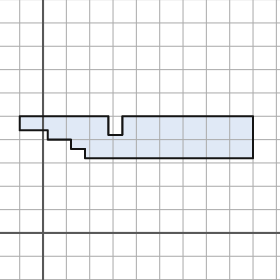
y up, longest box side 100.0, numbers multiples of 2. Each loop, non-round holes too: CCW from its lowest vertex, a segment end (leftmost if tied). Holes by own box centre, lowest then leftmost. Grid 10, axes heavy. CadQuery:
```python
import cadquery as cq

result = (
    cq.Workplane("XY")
    .moveTo(18.0, 32.0)
    .lineTo(90.0, 32.0)
    .lineTo(90.0, 50.0)
    .lineTo(34.0, 50.0)
    .lineTo(34.0, 42.0)
    .lineTo(28.0, 42.0)
    .lineTo(28.0, 50.0)
    .lineTo(-10.0, 50.0)
    .lineTo(-10.0, 44.0)
    .lineTo(2.0, 44.0)
    .lineTo(2.0, 40.0)
    .lineTo(12.0, 40.0)
    .lineTo(12.0, 36.0)
    .lineTo(18.0, 36.0)
    .close()
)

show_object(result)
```